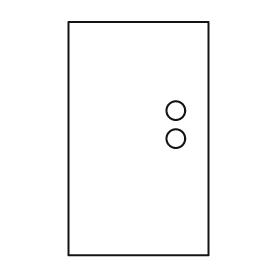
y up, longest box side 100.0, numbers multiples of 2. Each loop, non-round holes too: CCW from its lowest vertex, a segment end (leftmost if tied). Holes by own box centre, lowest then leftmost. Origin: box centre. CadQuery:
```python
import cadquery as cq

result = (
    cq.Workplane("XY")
    .moveTo(-30.0, -50.0)
    .lineTo(30.0, -50.0)
    .lineTo(30.0, 50.0)
    .lineTo(-30.0, 50.0)
    .close()
    .moveTo(16.0, 0.0)
    .circle(4.0)
    .moveTo(16.0, 12.0)
    .circle(4.0)
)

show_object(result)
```